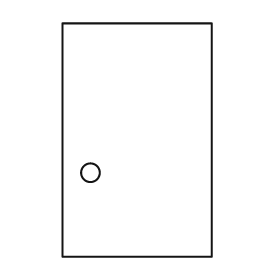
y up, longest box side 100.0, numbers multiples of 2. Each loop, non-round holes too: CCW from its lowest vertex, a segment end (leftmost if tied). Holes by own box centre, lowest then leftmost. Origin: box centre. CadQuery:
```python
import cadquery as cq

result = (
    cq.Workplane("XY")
    .moveTo(-32.0, -50.0)
    .lineTo(32.0, -50.0)
    .lineTo(32.0, 50.0)
    .lineTo(-32.0, 50.0)
    .close()
    .moveTo(-20.0, -14.0)
    .circle(4.0)
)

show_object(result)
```